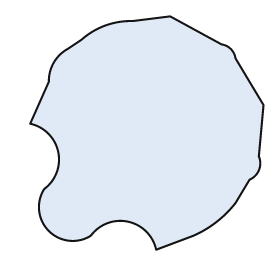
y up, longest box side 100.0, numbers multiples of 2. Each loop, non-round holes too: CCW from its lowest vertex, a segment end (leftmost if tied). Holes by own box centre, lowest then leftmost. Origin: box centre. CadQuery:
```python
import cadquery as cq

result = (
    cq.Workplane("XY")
    .moveTo(4.0, -50.0)
    .lineTo(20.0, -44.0)
    .threePointArc((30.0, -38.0), (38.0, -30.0))
    .lineTo(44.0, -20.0)
    .threePointArc((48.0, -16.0), (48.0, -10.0))
    .lineTo(50.0, 12.0)
    .lineTo(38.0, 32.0)
    .threePointArc((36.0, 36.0), (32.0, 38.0))
    .lineTo(10.0, 50.0)
    .lineTo(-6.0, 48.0)
    .threePointArc((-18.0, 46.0), (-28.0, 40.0))
    .lineTo(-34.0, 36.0)
    .threePointArc((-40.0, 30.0), (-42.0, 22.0))
    .lineTo(-50.0, 4.0)
    .threePointArc((-38.0, -8.0), (-44.0, -24.0))
    .threePointArc((-42.0, -42.0), (-24.0, -44.0))
    .threePointArc((-8.0, -38.0), (4.0, -50.0))
    .close()
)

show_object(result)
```